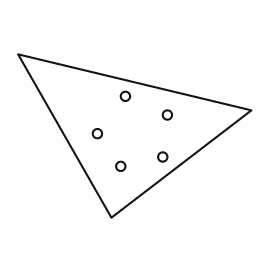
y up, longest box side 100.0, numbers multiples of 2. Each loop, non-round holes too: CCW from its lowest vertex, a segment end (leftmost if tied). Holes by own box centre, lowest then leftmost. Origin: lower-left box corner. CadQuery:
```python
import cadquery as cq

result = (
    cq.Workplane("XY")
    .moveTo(40.0, 0.0)
    .lineTo(100.0, 46.0)
    .lineTo(0.0, 70.0)
    .close()
    .moveTo(44.0, 22.0)
    .circle(2.0)
    .moveTo(62.0, 26.0)
    .circle(2.0)
    .moveTo(34.0, 36.0)
    .circle(2.0)
    .moveTo(64.0, 44.0)
    .circle(2.0)
    .moveTo(46.0, 52.0)
    .circle(2.0)
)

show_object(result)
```